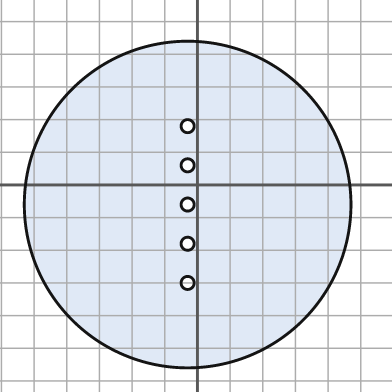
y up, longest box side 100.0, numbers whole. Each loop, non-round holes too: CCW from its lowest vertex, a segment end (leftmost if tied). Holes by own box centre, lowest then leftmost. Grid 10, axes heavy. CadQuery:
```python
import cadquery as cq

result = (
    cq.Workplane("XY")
    .moveTo(-3.0, -6.0)
    .circle(50.0)
    .moveTo(-3.0, -30.0)
    .circle(2.0)
    .moveTo(-3.0, -18.0)
    .circle(2.0)
    .moveTo(-3.0, -6.0)
    .circle(2.0)
    .moveTo(-3.0, 6.0)
    .circle(2.0)
    .moveTo(-3.0, 18.0)
    .circle(2.0)
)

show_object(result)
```